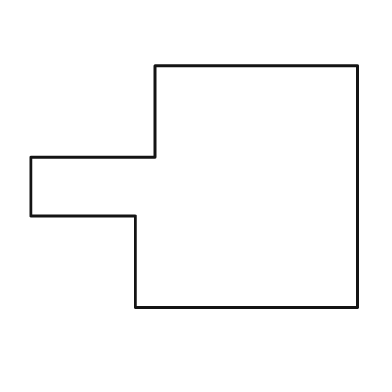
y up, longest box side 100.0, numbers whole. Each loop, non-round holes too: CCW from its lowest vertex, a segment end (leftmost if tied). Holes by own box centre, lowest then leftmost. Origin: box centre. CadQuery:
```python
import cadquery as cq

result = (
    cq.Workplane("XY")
    .moveTo(-18.0, -37.0)
    .lineTo(50.0, -37.0)
    .lineTo(50.0, 37.0)
    .lineTo(-12.0, 37.0)
    .lineTo(-12.0, 9.0)
    .lineTo(-50.0, 9.0)
    .lineTo(-50.0, -9.0)
    .lineTo(-18.0, -9.0)
    .close()
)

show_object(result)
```